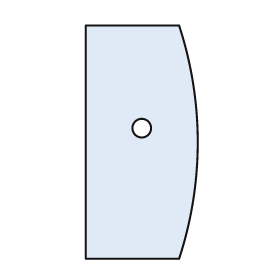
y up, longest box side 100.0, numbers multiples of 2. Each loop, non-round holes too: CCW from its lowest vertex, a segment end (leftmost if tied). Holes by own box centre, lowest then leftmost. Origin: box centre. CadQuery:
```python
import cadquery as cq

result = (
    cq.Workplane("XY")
    .moveTo(-24.0, -50.0)
    .lineTo(16.0, -50.0)
    .threePointArc((24.0, 0.0), (16.0, 50.0))
    .lineTo(-24.0, 50.0)
    .close()
    .moveTo(0.0, 6.0)
    .circle(4.0)
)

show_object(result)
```